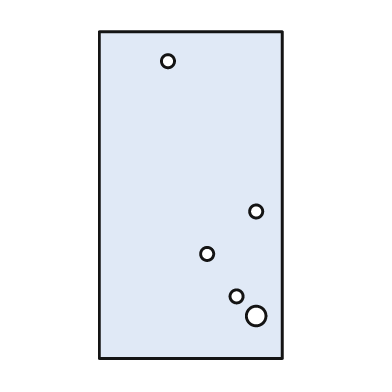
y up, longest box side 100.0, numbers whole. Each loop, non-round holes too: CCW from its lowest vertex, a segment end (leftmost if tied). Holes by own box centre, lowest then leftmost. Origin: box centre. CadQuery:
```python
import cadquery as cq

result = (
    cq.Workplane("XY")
    .moveTo(-28.0, -50.0)
    .lineTo(28.0, -50.0)
    .lineTo(28.0, 50.0)
    .lineTo(-28.0, 50.0)
    .close()
    .moveTo(20.0, -37.0)
    .circle(3.0)
    .moveTo(14.0, -31.0)
    .circle(2.0)
    .moveTo(5.0, -18.0)
    .circle(2.0)
    .moveTo(20.0, -5.0)
    .circle(2.0)
    .moveTo(-7.0, 41.0)
    .circle(2.0)
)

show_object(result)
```